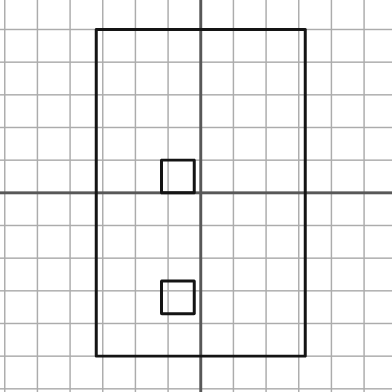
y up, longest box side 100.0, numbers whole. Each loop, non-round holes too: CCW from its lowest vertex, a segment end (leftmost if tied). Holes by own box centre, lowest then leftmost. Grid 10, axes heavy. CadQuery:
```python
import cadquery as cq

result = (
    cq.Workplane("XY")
    .moveTo(-32.0, -50.0)
    .lineTo(32.0, -50.0)
    .lineTo(32.0, 50.0)
    .lineTo(-32.0, 50.0)
    .close()
    .moveTo(-12.0, -37.0)
    .lineTo(-2.0, -37.0)
    .lineTo(-2.0, -27.0)
    .lineTo(-12.0, -27.0)
    .close()
    .moveTo(-12.0, 0.0)
    .lineTo(-2.0, 0.0)
    .lineTo(-2.0, 10.0)
    .lineTo(-12.0, 10.0)
    .close()
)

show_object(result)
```